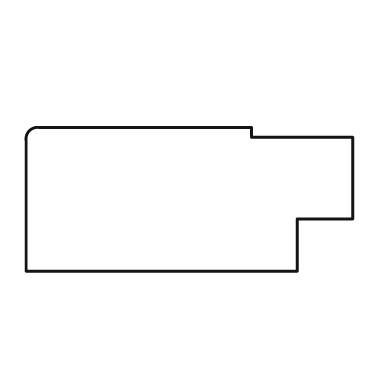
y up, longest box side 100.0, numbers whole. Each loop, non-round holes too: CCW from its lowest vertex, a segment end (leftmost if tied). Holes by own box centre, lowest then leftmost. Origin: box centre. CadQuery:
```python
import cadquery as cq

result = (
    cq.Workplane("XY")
    .moveTo(-50.0, -22.0)
    .lineTo(33.0, -22.0)
    .lineTo(33.0, -6.0)
    .lineTo(50.0, -6.0)
    .lineTo(50.0, 19.0)
    .lineTo(19.0, 19.0)
    .lineTo(19.0, 22.0)
    .lineTo(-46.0, 22.0)
    .threePointArc((-49.0, 21.0), (-50.0, 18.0))
    .close()
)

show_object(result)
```